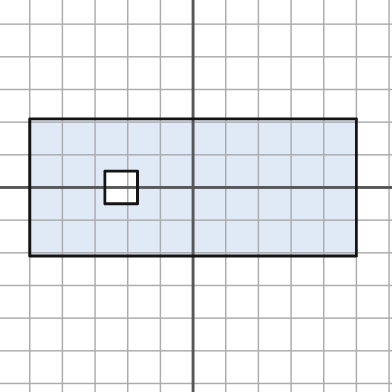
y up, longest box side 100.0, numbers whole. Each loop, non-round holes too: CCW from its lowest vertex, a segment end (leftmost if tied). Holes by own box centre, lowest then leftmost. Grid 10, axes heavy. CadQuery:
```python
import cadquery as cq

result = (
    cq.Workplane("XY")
    .moveTo(-50.0, -21.0)
    .lineTo(50.0, -21.0)
    .lineTo(50.0, 21.0)
    .lineTo(-50.0, 21.0)
    .close()
    .moveTo(-27.0, -5.0)
    .lineTo(-17.0, -5.0)
    .lineTo(-17.0, 5.0)
    .lineTo(-27.0, 5.0)
    .close()
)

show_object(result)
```